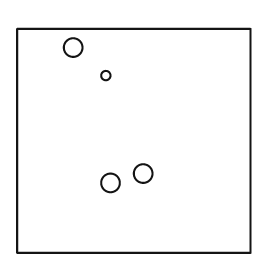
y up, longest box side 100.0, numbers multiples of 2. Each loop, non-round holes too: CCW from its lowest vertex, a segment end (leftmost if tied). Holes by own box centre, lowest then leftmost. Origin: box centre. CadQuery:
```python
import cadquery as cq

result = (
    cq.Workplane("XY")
    .moveTo(-50.0, -48.0)
    .lineTo(50.0, -48.0)
    .lineTo(50.0, 48.0)
    .lineTo(-50.0, 48.0)
    .close()
    .moveTo(-10.0, -18.0)
    .circle(4.0)
    .moveTo(4.0, -14.0)
    .circle(4.0)
    .moveTo(-12.0, 28.0)
    .circle(2.0)
    .moveTo(-26.0, 40.0)
    .circle(4.0)
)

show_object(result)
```